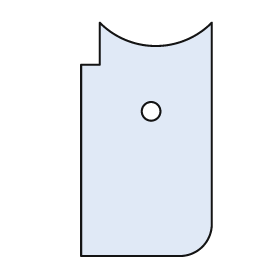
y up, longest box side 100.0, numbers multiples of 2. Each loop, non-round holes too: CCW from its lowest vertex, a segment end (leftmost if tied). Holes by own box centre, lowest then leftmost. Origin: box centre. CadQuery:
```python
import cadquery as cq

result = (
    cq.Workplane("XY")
    .moveTo(-28.0, -50.0)
    .lineTo(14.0, -50.0)
    .threePointArc((24.0, -46.0), (28.0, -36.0))
    .lineTo(28.0, 50.0)
    .threePointArc((4.0, 40.0), (-20.0, 50.0))
    .lineTo(-20.0, 32.0)
    .lineTo(-28.0, 32.0)
    .close()
    .moveTo(2.0, 12.0)
    .circle(4.0)
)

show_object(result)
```